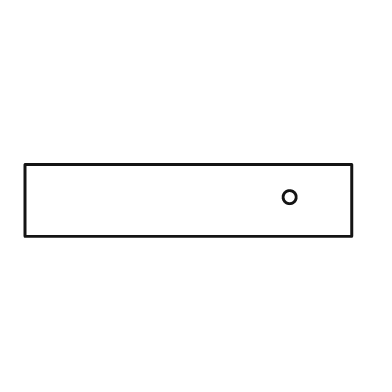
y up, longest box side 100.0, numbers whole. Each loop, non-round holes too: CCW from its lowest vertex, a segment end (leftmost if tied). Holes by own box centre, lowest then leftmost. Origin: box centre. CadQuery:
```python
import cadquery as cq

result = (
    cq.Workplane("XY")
    .moveTo(-50.0, -11.0)
    .lineTo(50.0, -11.0)
    .lineTo(50.0, 11.0)
    .lineTo(-50.0, 11.0)
    .close()
    .moveTo(31.0, 1.0)
    .circle(2.0)
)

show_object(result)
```